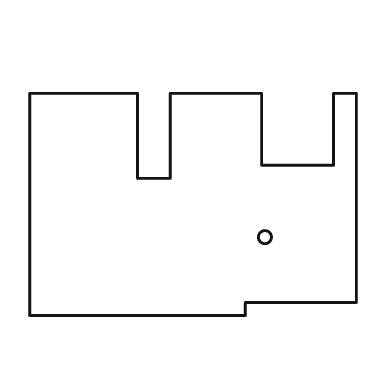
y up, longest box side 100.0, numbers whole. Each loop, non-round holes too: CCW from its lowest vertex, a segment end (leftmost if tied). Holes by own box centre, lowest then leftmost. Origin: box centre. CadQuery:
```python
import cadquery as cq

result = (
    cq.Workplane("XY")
    .moveTo(-50.0, -34.0)
    .lineTo(16.0, -34.0)
    .lineTo(16.0, -30.0)
    .lineTo(50.0, -30.0)
    .lineTo(50.0, 34.0)
    .lineTo(43.0, 34.0)
    .lineTo(43.0, 12.0)
    .lineTo(21.0, 12.0)
    .lineTo(21.0, 34.0)
    .lineTo(-7.0, 34.0)
    .lineTo(-7.0, 8.0)
    .lineTo(-17.0, 8.0)
    .lineTo(-17.0, 34.0)
    .lineTo(-50.0, 34.0)
    .close()
    .moveTo(22.0, -10.0)
    .circle(2.0)
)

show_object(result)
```